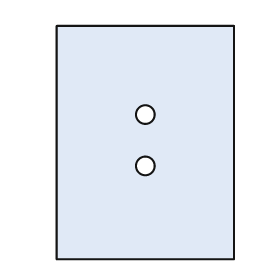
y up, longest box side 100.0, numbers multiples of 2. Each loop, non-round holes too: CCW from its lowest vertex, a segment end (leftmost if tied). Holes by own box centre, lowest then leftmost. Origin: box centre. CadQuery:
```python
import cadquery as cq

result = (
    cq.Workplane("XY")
    .moveTo(-38.0, -50.0)
    .lineTo(38.0, -50.0)
    .lineTo(38.0, 50.0)
    .lineTo(-38.0, 50.0)
    .close()
    .moveTo(0.0, -10.0)
    .circle(4.0)
    .moveTo(0.0, 12.0)
    .circle(4.0)
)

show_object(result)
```